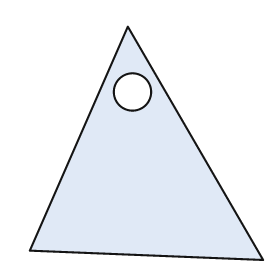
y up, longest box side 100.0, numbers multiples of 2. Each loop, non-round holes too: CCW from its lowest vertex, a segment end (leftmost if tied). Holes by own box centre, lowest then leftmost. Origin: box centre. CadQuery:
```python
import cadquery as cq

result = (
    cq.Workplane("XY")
    .moveTo(50.0, -50.0)
    .lineTo(-8.0, 50.0)
    .lineTo(-50.0, -46.0)
    .close()
    .moveTo(-6.0, 22.0)
    .circle(8.0)
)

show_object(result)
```